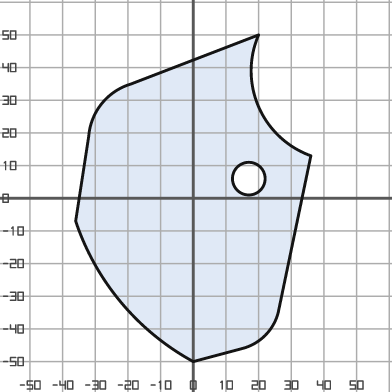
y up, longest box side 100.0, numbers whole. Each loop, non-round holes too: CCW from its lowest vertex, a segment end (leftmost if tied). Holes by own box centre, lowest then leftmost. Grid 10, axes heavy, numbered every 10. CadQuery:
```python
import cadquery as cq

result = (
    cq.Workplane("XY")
    .moveTo(0.0, -50.0)
    .lineTo(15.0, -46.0)
    .threePointArc((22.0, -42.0), (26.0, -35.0))
    .lineTo(36.0, 13.0)
    .threePointArc((20.0, 28.0), (20.0, 50.0))
    .lineTo(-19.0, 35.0)
    .threePointArc((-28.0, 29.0), (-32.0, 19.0))
    .lineTo(-36.0, -7.0)
    .threePointArc((-22.0, -32.0), (0.0, -50.0))
    .close()
    .moveTo(17.0, 6.0)
    .circle(5.0)
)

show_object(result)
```